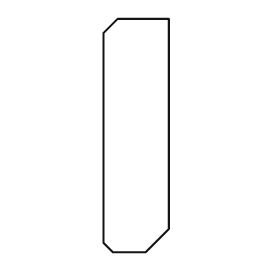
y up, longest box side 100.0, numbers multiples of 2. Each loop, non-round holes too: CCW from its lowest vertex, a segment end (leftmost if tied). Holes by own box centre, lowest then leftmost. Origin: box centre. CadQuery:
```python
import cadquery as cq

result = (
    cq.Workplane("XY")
    .moveTo(-10.0, -50.0)
    .lineTo(4.0, -50.0)
    .lineTo(14.0, -40.0)
    .lineTo(14.0, 50.0)
    .lineTo(-8.0, 50.0)
    .lineTo(-14.0, 44.0)
    .lineTo(-14.0, -46.0)
    .close()
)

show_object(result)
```